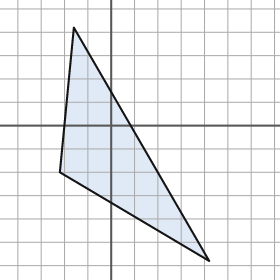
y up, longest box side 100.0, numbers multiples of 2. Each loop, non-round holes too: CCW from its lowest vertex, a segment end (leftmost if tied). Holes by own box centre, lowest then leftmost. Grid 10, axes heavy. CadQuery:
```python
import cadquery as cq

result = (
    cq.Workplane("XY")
    .moveTo(42.0, -58.0)
    .lineTo(-16.0, 42.0)
    .lineTo(-22.0, -20.0)
    .close()
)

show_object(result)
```